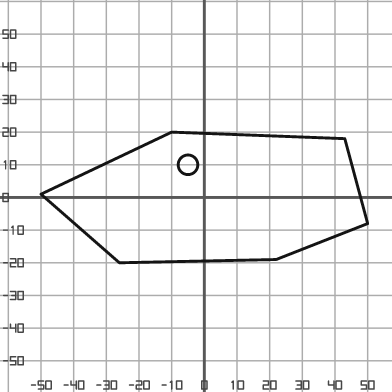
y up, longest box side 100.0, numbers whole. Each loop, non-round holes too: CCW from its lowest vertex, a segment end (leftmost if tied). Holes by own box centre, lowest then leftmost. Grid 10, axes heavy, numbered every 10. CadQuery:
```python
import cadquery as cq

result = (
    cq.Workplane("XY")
    .moveTo(-26.0, -20.0)
    .lineTo(22.0, -19.0)
    .lineTo(50.0, -8.0)
    .lineTo(43.0, 18.0)
    .lineTo(-10.0, 20.0)
    .lineTo(-50.0, 1.0)
    .close()
    .moveTo(-5.0, 10.0)
    .circle(3.0)
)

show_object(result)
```